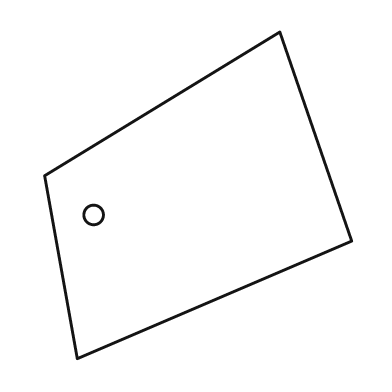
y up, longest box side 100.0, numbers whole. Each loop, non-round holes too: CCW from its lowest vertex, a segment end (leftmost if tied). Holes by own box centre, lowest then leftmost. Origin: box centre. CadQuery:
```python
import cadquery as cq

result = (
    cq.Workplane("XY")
    .moveTo(-37.0, -50.0)
    .lineTo(47.0, -14.0)
    .lineTo(25.0, 50.0)
    .lineTo(-47.0, 6.0)
    .close()
    .moveTo(-32.0, -6.0)
    .circle(3.0)
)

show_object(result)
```